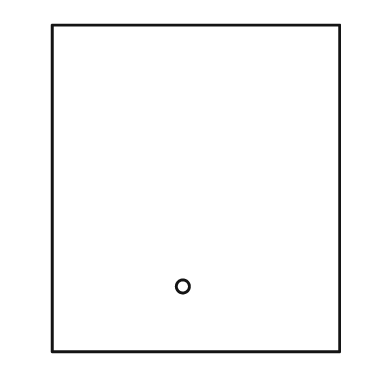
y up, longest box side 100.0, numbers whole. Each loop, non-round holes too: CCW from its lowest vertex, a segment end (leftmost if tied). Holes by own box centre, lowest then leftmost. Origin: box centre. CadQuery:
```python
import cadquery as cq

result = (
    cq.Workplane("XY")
    .moveTo(-44.0, -50.0)
    .lineTo(44.0, -50.0)
    .lineTo(44.0, 50.0)
    .lineTo(-44.0, 50.0)
    .close()
    .moveTo(-4.0, -30.0)
    .circle(2.0)
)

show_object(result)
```